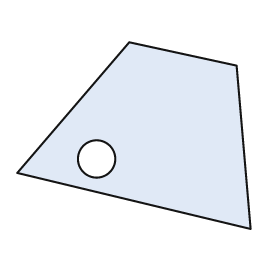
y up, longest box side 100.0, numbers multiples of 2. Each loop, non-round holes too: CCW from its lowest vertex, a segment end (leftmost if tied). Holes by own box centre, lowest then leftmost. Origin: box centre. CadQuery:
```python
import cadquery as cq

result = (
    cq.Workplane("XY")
    .moveTo(50.0, -40.0)
    .lineTo(44.0, 30.0)
    .lineTo(-2.0, 40.0)
    .lineTo(-50.0, -16.0)
    .close()
    .moveTo(-16.0, -10.0)
    .circle(8.0)
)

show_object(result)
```